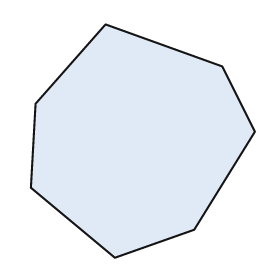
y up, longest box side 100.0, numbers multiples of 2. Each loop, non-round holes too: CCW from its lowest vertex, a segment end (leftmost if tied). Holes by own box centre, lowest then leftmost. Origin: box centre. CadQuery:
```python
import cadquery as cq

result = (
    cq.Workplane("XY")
    .moveTo(-12.0, -50.0)
    .lineTo(22.0, -38.0)
    .lineTo(48.0, 4.0)
    .lineTo(34.0, 32.0)
    .lineTo(-16.0, 50.0)
    .lineTo(-46.0, 16.0)
    .lineTo(-48.0, -20.0)
    .close()
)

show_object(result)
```